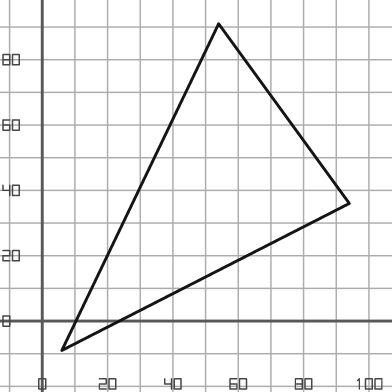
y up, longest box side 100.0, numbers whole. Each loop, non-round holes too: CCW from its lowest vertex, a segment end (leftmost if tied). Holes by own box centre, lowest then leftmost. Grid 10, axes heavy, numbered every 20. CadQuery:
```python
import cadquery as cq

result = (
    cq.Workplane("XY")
    .moveTo(6.0, -9.0)
    .lineTo(94.0, 36.0)
    .lineTo(54.0, 91.0)
    .close()
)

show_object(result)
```